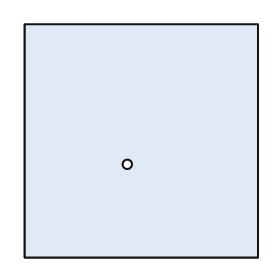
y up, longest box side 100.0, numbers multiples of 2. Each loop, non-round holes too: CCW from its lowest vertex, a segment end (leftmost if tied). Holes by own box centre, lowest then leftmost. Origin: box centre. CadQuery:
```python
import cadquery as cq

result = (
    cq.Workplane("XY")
    .moveTo(-50.0, -50.0)
    .lineTo(50.0, -50.0)
    .lineTo(50.0, 50.0)
    .lineTo(-50.0, 50.0)
    .close()
    .moveTo(-6.0, -10.0)
    .circle(2.0)
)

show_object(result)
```